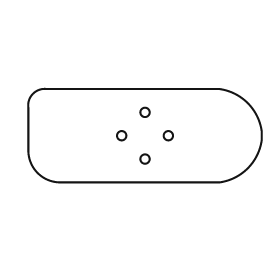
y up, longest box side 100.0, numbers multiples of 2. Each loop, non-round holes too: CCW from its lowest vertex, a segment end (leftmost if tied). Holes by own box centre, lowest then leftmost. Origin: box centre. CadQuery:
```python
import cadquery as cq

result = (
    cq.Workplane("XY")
    .moveTo(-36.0, -20.0)
    .lineTo(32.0, -20.0)
    .threePointArc((44.0, -14.0), (50.0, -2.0))
    .lineTo(50.0, 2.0)
    .threePointArc((44.0, 14.0), (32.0, 20.0))
    .lineTo(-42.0, 20.0)
    .threePointArc((-48.0, 18.0), (-50.0, 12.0))
    .lineTo(-50.0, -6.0)
    .threePointArc((-46.0, -16.0), (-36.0, -20.0))
    .close()
    .moveTo(0.0, -10.0)
    .circle(2.0)
    .moveTo(-10.0, 0.0)
    .circle(2.0)
    .moveTo(10.0, 0.0)
    .circle(2.0)
    .moveTo(0.0, 10.0)
    .circle(2.0)
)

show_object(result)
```